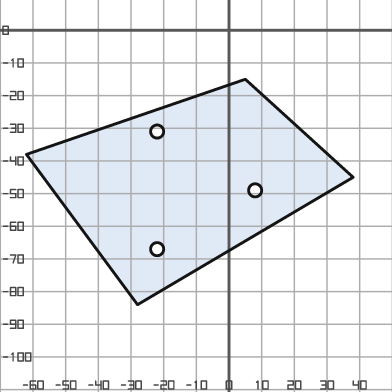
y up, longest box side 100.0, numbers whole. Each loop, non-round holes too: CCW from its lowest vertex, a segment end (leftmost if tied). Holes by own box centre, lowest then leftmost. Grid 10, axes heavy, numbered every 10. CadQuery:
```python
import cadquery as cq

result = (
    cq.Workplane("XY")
    .moveTo(-28.0, -84.0)
    .lineTo(38.0, -45.0)
    .lineTo(5.0, -15.0)
    .lineTo(-62.0, -38.0)
    .close()
    .moveTo(-22.0, -67.0)
    .circle(2.0)
    .moveTo(8.0, -49.0)
    .circle(2.0)
    .moveTo(-22.0, -31.0)
    .circle(2.0)
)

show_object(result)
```